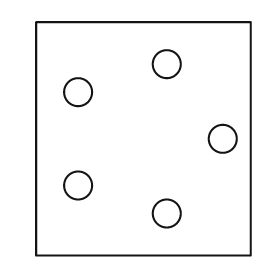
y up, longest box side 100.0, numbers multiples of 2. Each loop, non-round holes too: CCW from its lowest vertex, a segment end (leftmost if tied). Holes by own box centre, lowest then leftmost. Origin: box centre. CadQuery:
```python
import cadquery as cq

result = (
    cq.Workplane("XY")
    .moveTo(-46.0, -50.0)
    .lineTo(46.0, -50.0)
    .lineTo(46.0, 50.0)
    .lineTo(-46.0, 50.0)
    .close()
    .moveTo(10.0, -32.0)
    .circle(6.0)
    .moveTo(-28.0, -20.0)
    .circle(6.0)
    .moveTo(34.0, 0.0)
    .circle(6.0)
    .moveTo(-28.0, 20.0)
    .circle(6.0)
    .moveTo(10.0, 32.0)
    .circle(6.0)
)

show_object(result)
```